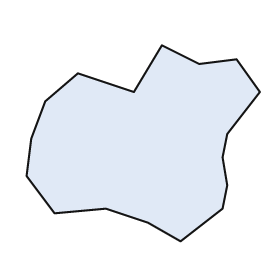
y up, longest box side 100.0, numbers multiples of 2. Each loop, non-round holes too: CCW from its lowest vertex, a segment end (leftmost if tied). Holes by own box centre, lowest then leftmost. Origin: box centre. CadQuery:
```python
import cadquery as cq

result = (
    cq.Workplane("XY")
    .moveTo(16.0, -42.0)
    .lineTo(34.0, -28.0)
    .lineTo(36.0, -18.0)
    .lineTo(34.0, -6.0)
    .lineTo(36.0, 4.0)
    .lineTo(50.0, 22.0)
    .lineTo(40.0, 36.0)
    .lineTo(24.0, 34.0)
    .lineTo(8.0, 42.0)
    .lineTo(-4.0, 22.0)
    .lineTo(-28.0, 30.0)
    .lineTo(-42.0, 18.0)
    .lineTo(-48.0, 2.0)
    .lineTo(-50.0, -14.0)
    .lineTo(-38.0, -30.0)
    .lineTo(-16.0, -28.0)
    .lineTo(2.0, -34.0)
    .close()
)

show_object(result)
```